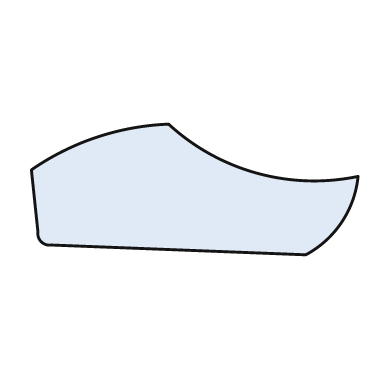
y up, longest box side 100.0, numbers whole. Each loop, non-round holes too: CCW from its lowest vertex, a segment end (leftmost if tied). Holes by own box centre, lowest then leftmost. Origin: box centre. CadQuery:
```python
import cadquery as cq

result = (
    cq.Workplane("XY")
    .moveTo(34.0, -20.0)
    .threePointArc((45.0, -10.0), (50.0, 4.0))
    .threePointArc((19.0, 5.0), (-8.0, 20.0))
    .threePointArc((-30.0, 16.0), (-50.0, 6.0))
    .lineTo(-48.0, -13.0)
    .threePointArc((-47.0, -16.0), (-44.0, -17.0))
    .close()
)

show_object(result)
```